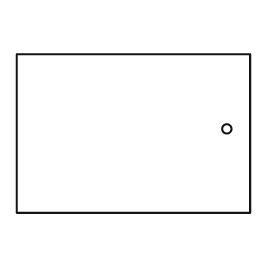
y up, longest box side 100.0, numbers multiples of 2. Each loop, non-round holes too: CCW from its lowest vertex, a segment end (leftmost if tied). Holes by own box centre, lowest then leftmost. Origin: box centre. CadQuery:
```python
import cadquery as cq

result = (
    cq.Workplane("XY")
    .moveTo(-50.0, -34.0)
    .lineTo(50.0, -34.0)
    .lineTo(50.0, 34.0)
    .lineTo(-50.0, 34.0)
    .close()
    .moveTo(40.0, 2.0)
    .circle(2.0)
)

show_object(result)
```